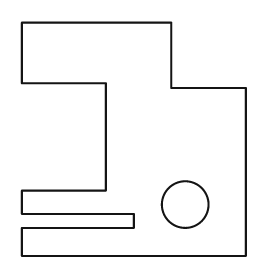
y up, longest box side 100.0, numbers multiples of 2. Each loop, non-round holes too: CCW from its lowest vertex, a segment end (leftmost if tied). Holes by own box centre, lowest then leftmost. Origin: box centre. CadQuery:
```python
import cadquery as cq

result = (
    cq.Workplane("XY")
    .moveTo(-48.0, -50.0)
    .lineTo(48.0, -50.0)
    .lineTo(48.0, 22.0)
    .lineTo(16.0, 22.0)
    .lineTo(16.0, 50.0)
    .lineTo(-48.0, 50.0)
    .lineTo(-48.0, 24.0)
    .lineTo(-12.0, 24.0)
    .lineTo(-12.0, -22.0)
    .lineTo(-48.0, -22.0)
    .lineTo(-48.0, -32.0)
    .lineTo(0.0, -32.0)
    .lineTo(0.0, -38.0)
    .lineTo(-48.0, -38.0)
    .close()
    .moveTo(22.0, -28.0)
    .circle(10.0)
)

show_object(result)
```